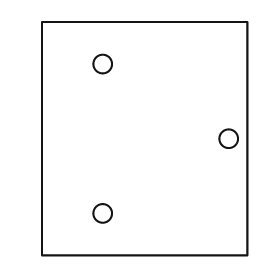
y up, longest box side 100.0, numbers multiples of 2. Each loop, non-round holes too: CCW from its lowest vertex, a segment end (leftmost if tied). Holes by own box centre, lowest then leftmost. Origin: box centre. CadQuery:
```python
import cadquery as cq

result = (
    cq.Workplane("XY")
    .moveTo(-44.0, -50.0)
    .lineTo(44.0, -50.0)
    .lineTo(44.0, 50.0)
    .lineTo(-44.0, 50.0)
    .close()
    .moveTo(-18.0, -32.0)
    .circle(4.0)
    .moveTo(36.0, 0.0)
    .circle(4.0)
    .moveTo(-18.0, 32.0)
    .circle(4.0)
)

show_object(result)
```